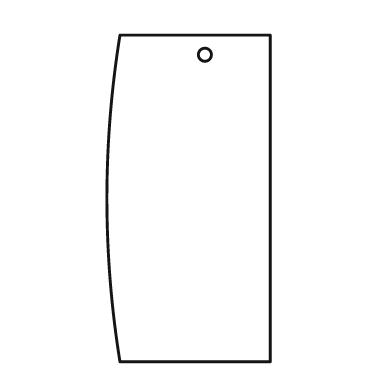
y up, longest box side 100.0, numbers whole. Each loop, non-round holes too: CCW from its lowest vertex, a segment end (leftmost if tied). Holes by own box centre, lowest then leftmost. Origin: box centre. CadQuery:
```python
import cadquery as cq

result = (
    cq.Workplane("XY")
    .moveTo(-21.0, -50.0)
    .lineTo(25.0, -50.0)
    .lineTo(25.0, 50.0)
    .lineTo(-21.0, 50.0)
    .threePointArc((-25.0, 0.0), (-21.0, -50.0))
    .close()
    .moveTo(5.0, 44.0)
    .circle(2.0)
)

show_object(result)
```